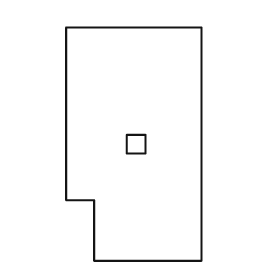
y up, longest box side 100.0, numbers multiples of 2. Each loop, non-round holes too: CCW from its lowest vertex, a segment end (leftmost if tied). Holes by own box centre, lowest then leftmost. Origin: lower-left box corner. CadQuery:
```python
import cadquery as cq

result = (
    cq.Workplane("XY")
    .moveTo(12.0, 0.0)
    .lineTo(58.0, 0.0)
    .lineTo(58.0, 100.0)
    .lineTo(0.0, 100.0)
    .lineTo(0.0, 26.0)
    .lineTo(12.0, 26.0)
    .close()
    .moveTo(26.0, 46.0)
    .lineTo(34.0, 46.0)
    .lineTo(34.0, 54.0)
    .lineTo(26.0, 54.0)
    .close()
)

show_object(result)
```